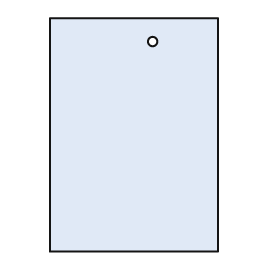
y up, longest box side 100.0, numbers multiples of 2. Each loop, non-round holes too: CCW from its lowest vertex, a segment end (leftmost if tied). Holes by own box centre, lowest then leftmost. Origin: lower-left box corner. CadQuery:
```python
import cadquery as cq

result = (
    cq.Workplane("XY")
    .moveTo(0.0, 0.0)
    .lineTo(72.0, 0.0)
    .lineTo(72.0, 100.0)
    .lineTo(0.0, 100.0)
    .close()
    .moveTo(44.0, 90.0)
    .circle(2.0)
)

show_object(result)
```